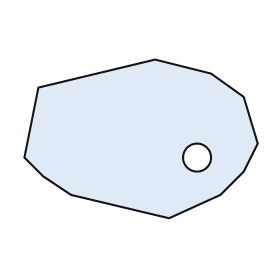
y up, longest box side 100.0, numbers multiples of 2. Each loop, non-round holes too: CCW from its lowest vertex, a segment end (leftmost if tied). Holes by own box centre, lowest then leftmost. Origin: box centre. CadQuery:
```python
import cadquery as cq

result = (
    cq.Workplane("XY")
    .moveTo(12.0, -34.0)
    .lineTo(34.0, -24.0)
    .lineTo(44.0, -14.0)
    .lineTo(50.0, -2.0)
    .lineTo(44.0, 18.0)
    .lineTo(30.0, 28.0)
    .lineTo(6.0, 34.0)
    .lineTo(-44.0, 22.0)
    .lineTo(-50.0, -8.0)
    .lineTo(-42.0, -16.0)
    .lineTo(-30.0, -24.0)
    .close()
    .moveTo(24.0, -8.0)
    .circle(6.0)
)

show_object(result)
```